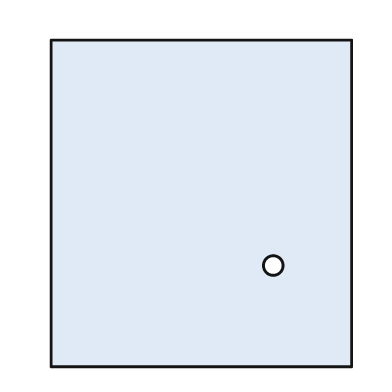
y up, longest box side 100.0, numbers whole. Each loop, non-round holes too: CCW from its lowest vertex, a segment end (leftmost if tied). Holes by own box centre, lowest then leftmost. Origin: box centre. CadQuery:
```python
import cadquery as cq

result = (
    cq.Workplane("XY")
    .moveTo(-46.0, -50.0)
    .lineTo(46.0, -50.0)
    .lineTo(46.0, 50.0)
    .lineTo(-46.0, 50.0)
    .close()
    .moveTo(22.0, -19.0)
    .circle(3.0)
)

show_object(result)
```